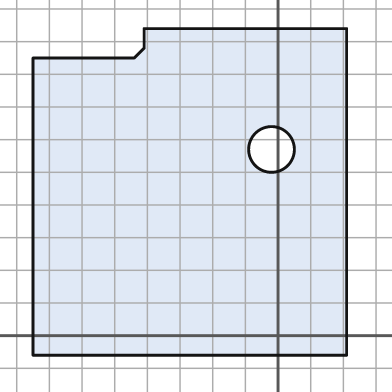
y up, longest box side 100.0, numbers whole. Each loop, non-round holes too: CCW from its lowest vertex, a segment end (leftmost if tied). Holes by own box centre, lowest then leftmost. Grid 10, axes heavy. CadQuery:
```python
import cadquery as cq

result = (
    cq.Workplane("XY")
    .moveTo(-75.0, -6.0)
    .lineTo(21.0, -6.0)
    .lineTo(21.0, 94.0)
    .lineTo(-41.0, 94.0)
    .lineTo(-41.0, 88.0)
    .lineTo(-44.0, 85.0)
    .lineTo(-75.0, 85.0)
    .close()
    .moveTo(-2.0, 57.0)
    .circle(7.0)
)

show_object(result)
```